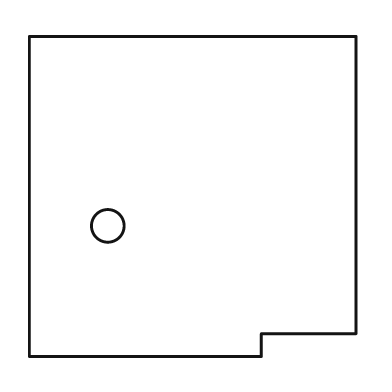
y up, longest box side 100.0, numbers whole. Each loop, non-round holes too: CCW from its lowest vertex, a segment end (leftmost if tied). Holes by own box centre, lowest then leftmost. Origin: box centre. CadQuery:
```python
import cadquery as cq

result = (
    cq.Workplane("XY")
    .moveTo(-50.0, -49.0)
    .lineTo(21.0, -49.0)
    .lineTo(21.0, -42.0)
    .lineTo(50.0, -42.0)
    .lineTo(50.0, 49.0)
    .lineTo(-50.0, 49.0)
    .close()
    .moveTo(-26.0, -9.0)
    .circle(5.0)
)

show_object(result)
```